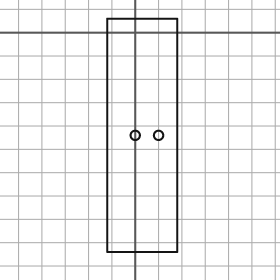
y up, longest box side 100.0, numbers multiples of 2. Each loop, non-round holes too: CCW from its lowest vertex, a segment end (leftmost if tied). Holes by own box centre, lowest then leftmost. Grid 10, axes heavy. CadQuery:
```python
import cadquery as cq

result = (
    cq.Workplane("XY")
    .moveTo(-12.0, -94.0)
    .lineTo(18.0, -94.0)
    .lineTo(18.0, 6.0)
    .lineTo(-12.0, 6.0)
    .close()
    .moveTo(0.0, -44.0)
    .circle(2.0)
    .moveTo(10.0, -44.0)
    .circle(2.0)
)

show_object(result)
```